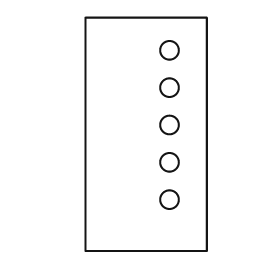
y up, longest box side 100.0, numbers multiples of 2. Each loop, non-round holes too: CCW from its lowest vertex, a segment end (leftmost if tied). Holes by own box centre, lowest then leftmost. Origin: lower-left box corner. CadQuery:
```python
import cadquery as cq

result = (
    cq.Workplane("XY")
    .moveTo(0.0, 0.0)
    .lineTo(52.0, 0.0)
    .lineTo(52.0, 100.0)
    .lineTo(0.0, 100.0)
    .close()
    .moveTo(36.0, 22.0)
    .circle(4.0)
    .moveTo(36.0, 38.0)
    .circle(4.0)
    .moveTo(36.0, 54.0)
    .circle(4.0)
    .moveTo(36.0, 70.0)
    .circle(4.0)
    .moveTo(36.0, 86.0)
    .circle(4.0)
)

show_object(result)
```